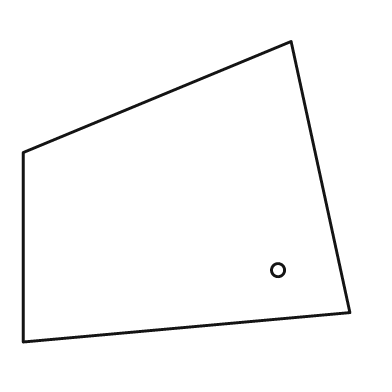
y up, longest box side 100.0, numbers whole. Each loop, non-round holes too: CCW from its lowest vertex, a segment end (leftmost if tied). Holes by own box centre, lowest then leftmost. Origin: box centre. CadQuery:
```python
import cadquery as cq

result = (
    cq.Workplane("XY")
    .moveTo(-50.0, -46.0)
    .lineTo(50.0, -37.0)
    .lineTo(32.0, 46.0)
    .lineTo(-50.0, 12.0)
    .close()
    .moveTo(28.0, -24.0)
    .circle(2.0)
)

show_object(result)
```